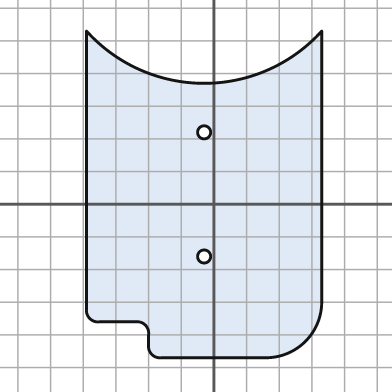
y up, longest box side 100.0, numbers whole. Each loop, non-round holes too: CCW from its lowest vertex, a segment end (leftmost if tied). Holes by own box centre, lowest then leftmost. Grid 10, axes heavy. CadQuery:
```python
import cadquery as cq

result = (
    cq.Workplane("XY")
    .moveTo(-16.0, -47.0)
    .lineTo(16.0, -47.0)
    .threePointArc((28.0, -42.0), (33.0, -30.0))
    .lineTo(33.0, 53.0)
    .threePointArc((-3.0, 37.0), (-39.0, 53.0))
    .lineTo(-39.0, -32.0)
    .threePointArc((-38.0, -35.0), (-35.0, -36.0))
    .lineTo(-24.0, -36.0)
    .threePointArc((-21.0, -37.0), (-20.0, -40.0))
    .lineTo(-20.0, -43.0)
    .threePointArc((-19.0, -46.0), (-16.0, -47.0))
    .close()
    .moveTo(-3.0, -16.0)
    .circle(2.0)
    .moveTo(-3.0, 22.0)
    .circle(2.0)
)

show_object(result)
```